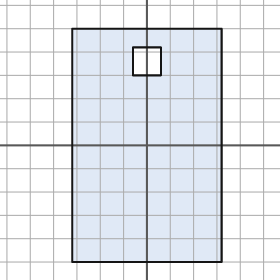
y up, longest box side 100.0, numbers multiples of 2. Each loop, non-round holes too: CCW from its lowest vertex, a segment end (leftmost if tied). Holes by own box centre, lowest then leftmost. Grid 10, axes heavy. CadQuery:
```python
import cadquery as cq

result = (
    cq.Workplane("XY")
    .moveTo(-32.0, -50.0)
    .lineTo(32.0, -50.0)
    .lineTo(32.0, 50.0)
    .lineTo(-32.0, 50.0)
    .close()
    .moveTo(-6.0, 30.0)
    .lineTo(6.0, 30.0)
    .lineTo(6.0, 42.0)
    .lineTo(-6.0, 42.0)
    .close()
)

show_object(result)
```